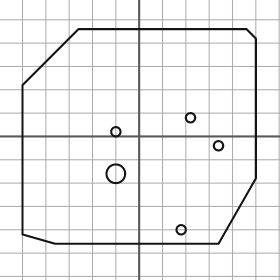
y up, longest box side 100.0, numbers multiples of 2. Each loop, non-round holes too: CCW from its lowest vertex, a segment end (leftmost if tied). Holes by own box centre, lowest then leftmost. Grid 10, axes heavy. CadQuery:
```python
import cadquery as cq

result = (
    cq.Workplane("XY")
    .moveTo(-36.0, -46.0)
    .lineTo(34.0, -46.0)
    .lineTo(50.0, -18.0)
    .lineTo(50.0, 42.0)
    .lineTo(46.0, 46.0)
    .lineTo(-26.0, 46.0)
    .lineTo(-50.0, 22.0)
    .lineTo(-50.0, -42.0)
    .close()
    .moveTo(18.0, -40.0)
    .circle(2.0)
    .moveTo(-10.0, -16.0)
    .circle(4.0)
    .moveTo(34.0, -4.0)
    .circle(2.0)
    .moveTo(-10.0, 2.0)
    .circle(2.0)
    .moveTo(22.0, 8.0)
    .circle(2.0)
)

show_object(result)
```